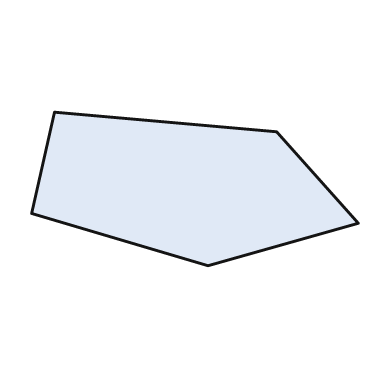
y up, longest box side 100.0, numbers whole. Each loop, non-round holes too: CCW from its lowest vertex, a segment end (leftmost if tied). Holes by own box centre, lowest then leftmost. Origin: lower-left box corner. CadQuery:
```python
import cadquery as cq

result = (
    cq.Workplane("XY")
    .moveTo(54.0, 0.0)
    .lineTo(100.0, 13.0)
    .lineTo(75.0, 41.0)
    .lineTo(7.0, 47.0)
    .lineTo(0.0, 16.0)
    .close()
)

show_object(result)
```